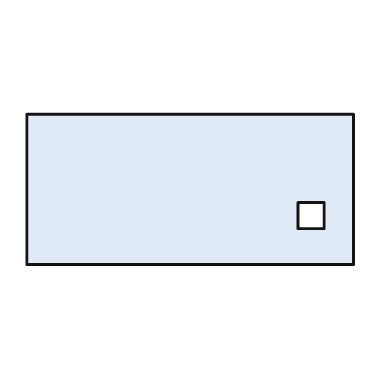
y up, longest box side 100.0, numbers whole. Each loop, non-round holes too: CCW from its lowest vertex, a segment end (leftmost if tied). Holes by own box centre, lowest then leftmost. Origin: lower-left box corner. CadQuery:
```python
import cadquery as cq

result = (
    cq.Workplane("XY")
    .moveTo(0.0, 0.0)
    .lineTo(100.0, 0.0)
    .lineTo(100.0, 46.0)
    .lineTo(0.0, 46.0)
    .close()
    .moveTo(83.0, 11.0)
    .lineTo(91.0, 11.0)
    .lineTo(91.0, 19.0)
    .lineTo(83.0, 19.0)
    .close()
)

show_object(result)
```